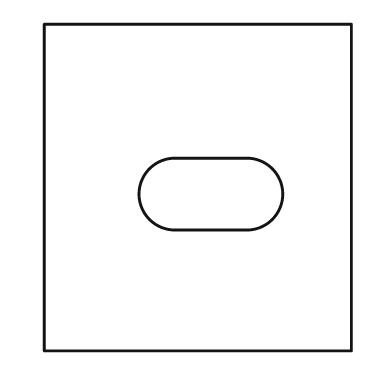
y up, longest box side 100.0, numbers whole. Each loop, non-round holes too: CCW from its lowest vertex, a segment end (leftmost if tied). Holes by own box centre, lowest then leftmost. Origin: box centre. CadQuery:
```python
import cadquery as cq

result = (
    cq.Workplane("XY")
    .moveTo(-47.0, -50.0)
    .lineTo(47.0, -50.0)
    .lineTo(47.0, 50.0)
    .lineTo(-47.0, 50.0)
    .close()
    .moveTo(-7.0, -13.0)
    .lineTo(15.0, -13.0)
    .threePointArc((26.0, -2.0), (15.0, 9.0))
    .lineTo(-7.0, 9.0)
    .threePointArc((-18.0, -2.0), (-7.0, -13.0))
    .close()
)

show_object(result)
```